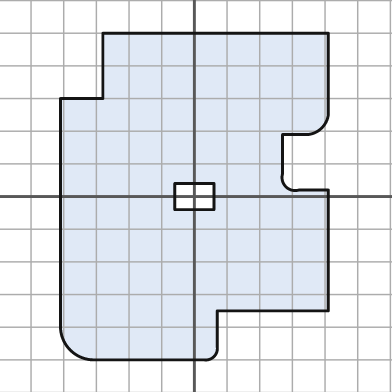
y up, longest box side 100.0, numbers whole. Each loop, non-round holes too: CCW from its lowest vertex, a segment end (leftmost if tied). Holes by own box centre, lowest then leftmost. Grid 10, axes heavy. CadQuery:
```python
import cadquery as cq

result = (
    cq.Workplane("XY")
    .moveTo(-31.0, -50.0)
    .lineTo(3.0, -50.0)
    .threePointArc((6.0, -49.0), (7.0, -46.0))
    .lineTo(7.0, -35.0)
    .lineTo(41.0, -35.0)
    .lineTo(41.0, 2.0)
    .lineTo(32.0, 2.0)
    .threePointArc((28.0, 3.0), (27.0, 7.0))
    .lineTo(27.0, 19.0)
    .lineTo(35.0, 19.0)
    .threePointArc((39.0, 21.0), (41.0, 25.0))
    .lineTo(41.0, 50.0)
    .lineTo(-28.0, 50.0)
    .lineTo(-28.0, 30.0)
    .lineTo(-41.0, 30.0)
    .lineTo(-41.0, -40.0)
    .threePointArc((-38.0, -47.0), (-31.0, -50.0))
    .close()
    .moveTo(-6.0, -4.0)
    .lineTo(6.0, -4.0)
    .lineTo(6.0, 4.0)
    .lineTo(-6.0, 4.0)
    .close()
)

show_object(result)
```